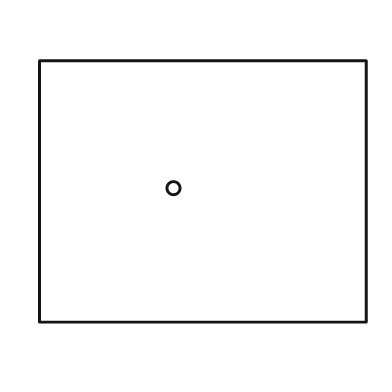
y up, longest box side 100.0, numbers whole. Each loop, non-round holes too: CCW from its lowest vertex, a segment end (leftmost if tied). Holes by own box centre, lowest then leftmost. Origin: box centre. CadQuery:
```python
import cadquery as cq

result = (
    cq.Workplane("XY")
    .moveTo(-50.0, -40.0)
    .lineTo(50.0, -40.0)
    .lineTo(50.0, 40.0)
    .lineTo(-50.0, 40.0)
    .close()
    .moveTo(-9.0, 1.0)
    .circle(2.0)
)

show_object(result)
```